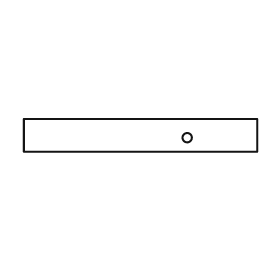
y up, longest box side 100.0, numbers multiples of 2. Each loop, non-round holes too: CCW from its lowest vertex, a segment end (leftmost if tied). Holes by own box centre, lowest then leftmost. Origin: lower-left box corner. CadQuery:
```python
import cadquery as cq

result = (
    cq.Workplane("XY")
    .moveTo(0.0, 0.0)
    .lineTo(100.0, 0.0)
    .lineTo(100.0, 14.0)
    .lineTo(0.0, 14.0)
    .close()
    .moveTo(70.0, 6.0)
    .circle(2.0)
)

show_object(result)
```